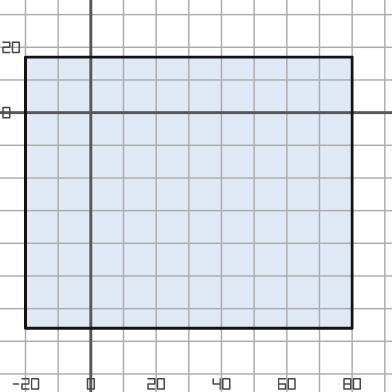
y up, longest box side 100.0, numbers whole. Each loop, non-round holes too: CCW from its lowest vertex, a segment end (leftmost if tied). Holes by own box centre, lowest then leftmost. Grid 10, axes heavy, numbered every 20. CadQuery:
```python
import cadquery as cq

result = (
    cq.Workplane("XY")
    .moveTo(-20.0, -66.0)
    .lineTo(80.0, -66.0)
    .lineTo(80.0, 17.0)
    .lineTo(-20.0, 17.0)
    .close()
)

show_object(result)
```